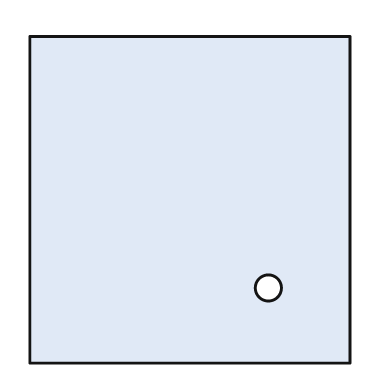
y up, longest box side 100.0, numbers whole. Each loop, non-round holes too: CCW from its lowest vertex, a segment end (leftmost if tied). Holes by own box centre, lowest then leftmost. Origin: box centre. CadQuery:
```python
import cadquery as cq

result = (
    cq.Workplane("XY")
    .moveTo(-49.0, -50.0)
    .lineTo(49.0, -50.0)
    .lineTo(49.0, 50.0)
    .lineTo(-49.0, 50.0)
    .close()
    .moveTo(24.0, -27.0)
    .circle(4.0)
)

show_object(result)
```